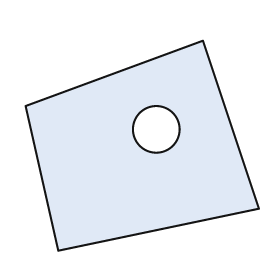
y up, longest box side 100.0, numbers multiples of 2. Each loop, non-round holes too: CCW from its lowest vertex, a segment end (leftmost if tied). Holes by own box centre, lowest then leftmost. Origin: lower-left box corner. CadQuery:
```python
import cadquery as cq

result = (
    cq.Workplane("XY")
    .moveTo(14.0, 0.0)
    .lineTo(100.0, 18.0)
    .lineTo(76.0, 90.0)
    .lineTo(0.0, 62.0)
    .close()
    .moveTo(56.0, 52.0)
    .circle(10.0)
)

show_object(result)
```